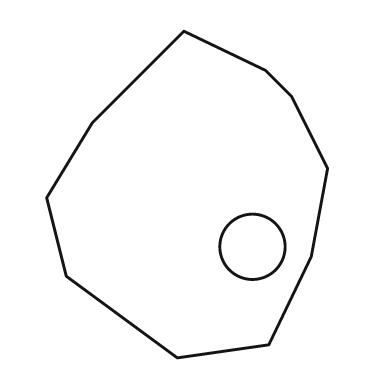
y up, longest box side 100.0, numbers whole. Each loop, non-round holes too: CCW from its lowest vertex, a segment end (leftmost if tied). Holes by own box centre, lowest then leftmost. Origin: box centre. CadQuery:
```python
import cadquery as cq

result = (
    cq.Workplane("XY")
    .moveTo(-3.0, -50.0)
    .lineTo(25.0, -46.0)
    .lineTo(38.0, -19.0)
    .lineTo(43.0, 8.0)
    .lineTo(32.0, 30.0)
    .lineTo(24.0, 38.0)
    .lineTo(-1.0, 50.0)
    .lineTo(-29.0, 22.0)
    .lineTo(-43.0, -1.0)
    .lineTo(-37.0, -25.0)
    .close()
    .moveTo(20.0, -16.0)
    .circle(10.0)
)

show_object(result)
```